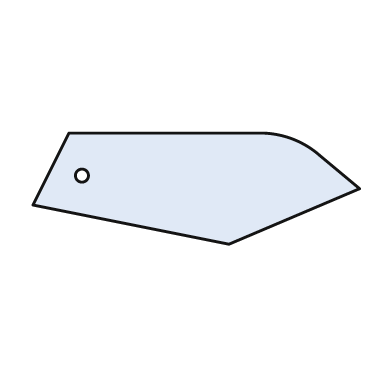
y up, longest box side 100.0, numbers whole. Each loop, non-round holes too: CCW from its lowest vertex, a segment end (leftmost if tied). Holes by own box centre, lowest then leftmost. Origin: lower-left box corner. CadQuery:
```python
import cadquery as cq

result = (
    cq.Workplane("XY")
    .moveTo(60.0, 0.0)
    .lineTo(100.0, 17.0)
    .lineTo(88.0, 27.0)
    .threePointArc((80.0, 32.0), (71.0, 34.0))
    .lineTo(11.0, 34.0)
    .lineTo(0.0, 12.0)
    .close()
    .moveTo(15.0, 21.0)
    .circle(2.0)
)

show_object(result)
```